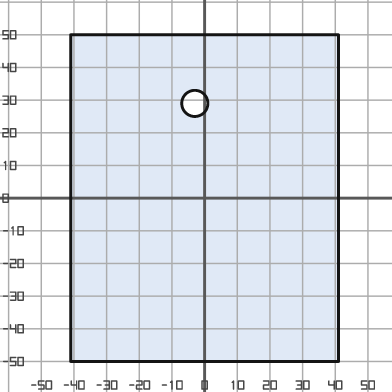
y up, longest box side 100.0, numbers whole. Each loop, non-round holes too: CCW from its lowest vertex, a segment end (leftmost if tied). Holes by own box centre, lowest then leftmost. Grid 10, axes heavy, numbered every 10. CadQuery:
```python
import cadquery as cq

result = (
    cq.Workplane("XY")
    .moveTo(-41.0, -50.0)
    .lineTo(41.0, -50.0)
    .lineTo(41.0, 50.0)
    .lineTo(-41.0, 50.0)
    .close()
    .moveTo(-3.0, 29.0)
    .circle(4.0)
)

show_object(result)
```